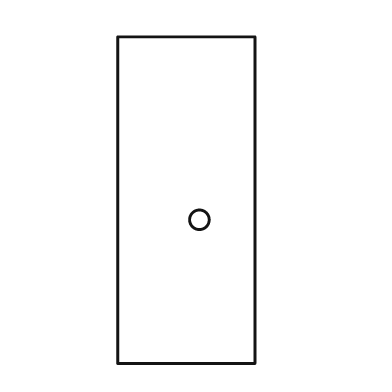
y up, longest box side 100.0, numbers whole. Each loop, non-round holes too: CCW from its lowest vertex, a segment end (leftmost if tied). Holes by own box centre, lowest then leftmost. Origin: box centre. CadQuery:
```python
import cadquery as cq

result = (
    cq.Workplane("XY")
    .moveTo(-21.0, -50.0)
    .lineTo(21.0, -50.0)
    .lineTo(21.0, 50.0)
    .lineTo(-21.0, 50.0)
    .close()
    .moveTo(4.0, -6.0)
    .circle(3.0)
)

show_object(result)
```